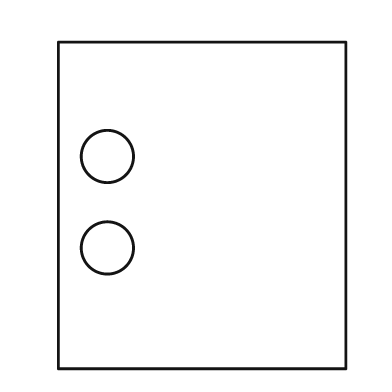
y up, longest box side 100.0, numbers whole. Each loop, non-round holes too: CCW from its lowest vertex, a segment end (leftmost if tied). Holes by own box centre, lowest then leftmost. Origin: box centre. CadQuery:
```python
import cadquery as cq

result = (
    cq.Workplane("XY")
    .moveTo(-44.0, -50.0)
    .lineTo(44.0, -50.0)
    .lineTo(44.0, 50.0)
    .lineTo(-44.0, 50.0)
    .close()
    .moveTo(-29.0, -13.0)
    .circle(8.0)
    .moveTo(-29.0, 15.0)
    .circle(8.0)
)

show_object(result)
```